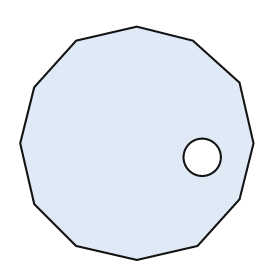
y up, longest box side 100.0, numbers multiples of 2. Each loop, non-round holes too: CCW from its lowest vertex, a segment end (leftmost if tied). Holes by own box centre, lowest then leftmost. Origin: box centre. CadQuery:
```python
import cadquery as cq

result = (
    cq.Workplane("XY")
    .moveTo(0.0, -50.0)
    .lineTo(26.0, -44.0)
    .lineTo(44.0, -24.0)
    .lineTo(50.0, 0.0)
    .lineTo(44.0, 26.0)
    .lineTo(24.0, 44.0)
    .lineTo(0.0, 50.0)
    .lineTo(-26.0, 44.0)
    .lineTo(-44.0, 24.0)
    .lineTo(-50.0, 0.0)
    .lineTo(-44.0, -26.0)
    .lineTo(-26.0, -44.0)
    .close()
    .moveTo(28.0, -6.0)
    .circle(8.0)
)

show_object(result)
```